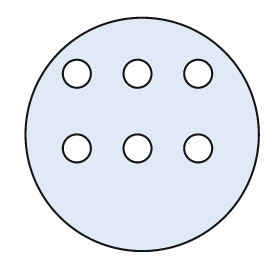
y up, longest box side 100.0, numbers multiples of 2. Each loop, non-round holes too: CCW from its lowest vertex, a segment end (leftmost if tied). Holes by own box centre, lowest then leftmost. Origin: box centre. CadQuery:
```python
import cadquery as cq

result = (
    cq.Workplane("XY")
    .moveTo(0.0, 0.0)
    .circle(50.0)
    .moveTo(-28.0, -6.0)
    .circle(6.0)
    .moveTo(-2.0, -6.0)
    .circle(6.0)
    .moveTo(24.0, -6.0)
    .circle(6.0)
    .moveTo(-28.0, 26.0)
    .circle(6.0)
    .moveTo(-2.0, 26.0)
    .circle(6.0)
    .moveTo(24.0, 26.0)
    .circle(6.0)
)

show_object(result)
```